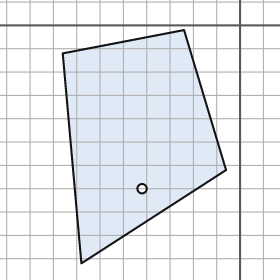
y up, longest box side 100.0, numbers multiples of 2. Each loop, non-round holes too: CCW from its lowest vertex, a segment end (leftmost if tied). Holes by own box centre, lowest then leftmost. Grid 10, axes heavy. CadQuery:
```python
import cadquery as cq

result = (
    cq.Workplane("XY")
    .moveTo(-68.0, -102.0)
    .lineTo(-6.0, -62.0)
    .lineTo(-24.0, -2.0)
    .lineTo(-76.0, -12.0)
    .close()
    .moveTo(-42.0, -70.0)
    .circle(2.0)
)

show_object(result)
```